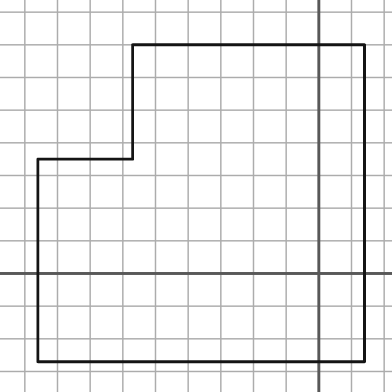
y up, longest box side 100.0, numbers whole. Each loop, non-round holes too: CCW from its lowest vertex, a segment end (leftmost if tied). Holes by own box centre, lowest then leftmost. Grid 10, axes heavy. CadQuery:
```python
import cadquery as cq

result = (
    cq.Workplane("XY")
    .moveTo(-86.0, -27.0)
    .lineTo(14.0, -27.0)
    .lineTo(14.0, 70.0)
    .lineTo(-57.0, 70.0)
    .lineTo(-57.0, 35.0)
    .lineTo(-86.0, 35.0)
    .close()
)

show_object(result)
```